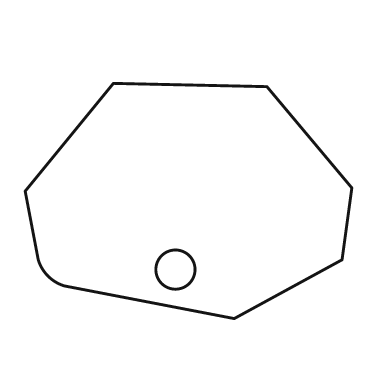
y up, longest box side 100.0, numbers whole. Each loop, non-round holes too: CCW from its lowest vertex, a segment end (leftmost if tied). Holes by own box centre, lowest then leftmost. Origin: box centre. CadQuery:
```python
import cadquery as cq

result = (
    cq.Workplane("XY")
    .moveTo(14.0, -36.0)
    .lineTo(47.0, -18.0)
    .lineTo(50.0, 4.0)
    .lineTo(24.0, 35.0)
    .lineTo(-23.0, 36.0)
    .lineTo(-50.0, 3.0)
    .lineTo(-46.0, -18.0)
    .threePointArc((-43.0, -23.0), (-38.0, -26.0))
    .close()
    .moveTo(-4.0, -21.0)
    .circle(6.0)
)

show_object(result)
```